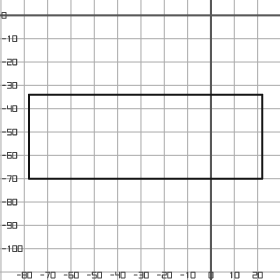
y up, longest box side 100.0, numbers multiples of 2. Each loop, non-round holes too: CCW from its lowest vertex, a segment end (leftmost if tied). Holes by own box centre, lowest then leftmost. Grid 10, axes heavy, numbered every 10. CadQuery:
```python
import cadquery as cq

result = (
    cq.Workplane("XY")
    .moveTo(-78.0, -70.0)
    .lineTo(22.0, -70.0)
    .lineTo(22.0, -34.0)
    .lineTo(-78.0, -34.0)
    .close()
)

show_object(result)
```